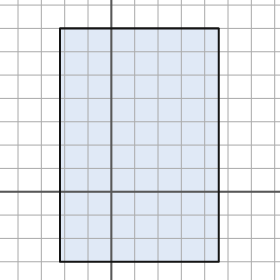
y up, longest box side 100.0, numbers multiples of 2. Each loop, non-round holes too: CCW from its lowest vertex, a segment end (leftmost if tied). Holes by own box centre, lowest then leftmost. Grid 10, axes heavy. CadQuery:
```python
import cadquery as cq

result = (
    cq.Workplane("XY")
    .moveTo(-22.0, -30.0)
    .lineTo(46.0, -30.0)
    .lineTo(46.0, 70.0)
    .lineTo(-22.0, 70.0)
    .close()
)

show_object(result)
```